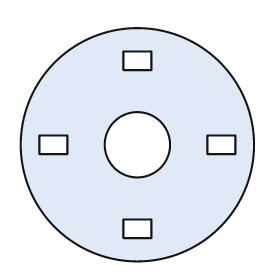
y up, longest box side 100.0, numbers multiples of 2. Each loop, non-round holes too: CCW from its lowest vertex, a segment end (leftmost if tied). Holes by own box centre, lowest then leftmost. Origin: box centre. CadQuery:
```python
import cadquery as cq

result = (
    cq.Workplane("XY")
    .moveTo(0.0, 0.0)
    .circle(50.0)
    .moveTo(-6.0, -40.0)
    .lineTo(6.0, -40.0)
    .lineTo(6.0, -32.0)
    .lineTo(-6.0, -32.0)
    .close()
    .moveTo(-42.0, -4.0)
    .lineTo(-30.0, -4.0)
    .lineTo(-30.0, 4.0)
    .lineTo(-42.0, 4.0)
    .close()
    .moveTo(0.0, 0.0)
    .circle(14.0)
    .moveTo(30.0, -4.0)
    .lineTo(42.0, -4.0)
    .lineTo(42.0, 4.0)
    .lineTo(30.0, 4.0)
    .close()
    .moveTo(-6.0, 32.0)
    .lineTo(6.0, 32.0)
    .lineTo(6.0, 40.0)
    .lineTo(-6.0, 40.0)
    .close()
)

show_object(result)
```